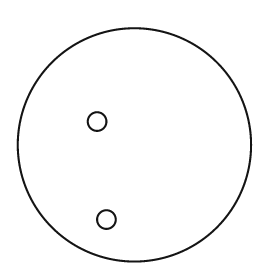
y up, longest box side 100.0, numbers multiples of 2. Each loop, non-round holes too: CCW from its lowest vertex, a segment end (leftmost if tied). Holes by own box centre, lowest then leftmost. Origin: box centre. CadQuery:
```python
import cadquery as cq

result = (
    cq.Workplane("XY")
    .moveTo(0.0, 0.0)
    .circle(50.0)
    .moveTo(-12.0, -32.0)
    .circle(4.0)
    .moveTo(-16.0, 10.0)
    .circle(4.0)
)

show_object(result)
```